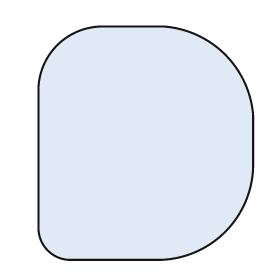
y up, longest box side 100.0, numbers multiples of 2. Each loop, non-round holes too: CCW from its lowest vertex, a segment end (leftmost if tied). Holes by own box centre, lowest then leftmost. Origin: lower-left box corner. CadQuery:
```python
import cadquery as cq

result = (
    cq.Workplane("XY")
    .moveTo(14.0, 0.0)
    .lineTo(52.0, 0.0)
    .threePointArc((80.0, 12.0), (92.0, 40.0))
    .lineTo(92.0, 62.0)
    .threePointArc((80.0, 88.0), (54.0, 100.0))
    .lineTo(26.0, 100.0)
    .threePointArc((8.0, 92.0), (0.0, 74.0))
    .lineTo(0.0, 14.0)
    .threePointArc((4.0, 4.0), (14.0, 0.0))
    .close()
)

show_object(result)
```